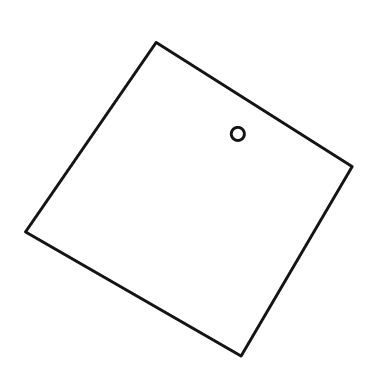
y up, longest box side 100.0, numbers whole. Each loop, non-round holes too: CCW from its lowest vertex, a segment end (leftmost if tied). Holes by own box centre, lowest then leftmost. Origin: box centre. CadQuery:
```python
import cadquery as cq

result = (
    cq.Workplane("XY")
    .moveTo(16.0, -48.0)
    .lineTo(50.0, 10.0)
    .lineTo(-10.0, 48.0)
    .lineTo(-50.0, -10.0)
    .close()
    .moveTo(15.0, 20.0)
    .circle(2.0)
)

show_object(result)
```